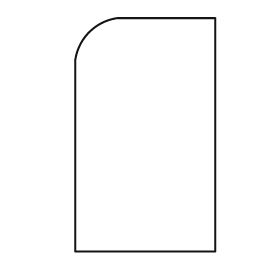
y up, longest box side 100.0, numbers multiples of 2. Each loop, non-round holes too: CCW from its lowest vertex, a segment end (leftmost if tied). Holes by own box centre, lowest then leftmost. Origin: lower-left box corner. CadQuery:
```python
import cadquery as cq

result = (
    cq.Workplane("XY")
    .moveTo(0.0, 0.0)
    .lineTo(60.0, 0.0)
    .lineTo(60.0, 100.0)
    .lineTo(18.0, 100.0)
    .threePointArc((6.0, 94.0), (0.0, 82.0))
    .close()
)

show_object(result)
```